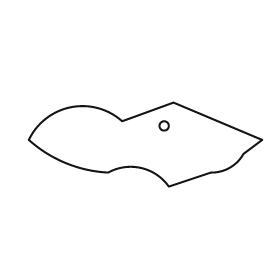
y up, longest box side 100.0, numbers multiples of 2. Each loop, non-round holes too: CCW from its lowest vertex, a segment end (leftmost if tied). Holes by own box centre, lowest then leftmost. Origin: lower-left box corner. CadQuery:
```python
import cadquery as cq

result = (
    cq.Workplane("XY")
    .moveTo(60.0, 0.0)
    .lineTo(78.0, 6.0)
    .threePointArc((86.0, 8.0), (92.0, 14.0))
    .lineTo(100.0, 20.0)
    .lineTo(62.0, 36.0)
    .lineTo(40.0, 28.0)
    .threePointArc((18.0, 34.0), (0.0, 20.0))
    .threePointArc((16.0, 10.0), (34.0, 6.0))
    .threePointArc((48.0, 8.0), (60.0, 0.0))
    .close()
    .moveTo(58.0, 26.0)
    .circle(2.0)
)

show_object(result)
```